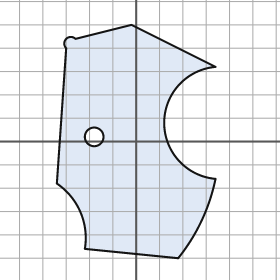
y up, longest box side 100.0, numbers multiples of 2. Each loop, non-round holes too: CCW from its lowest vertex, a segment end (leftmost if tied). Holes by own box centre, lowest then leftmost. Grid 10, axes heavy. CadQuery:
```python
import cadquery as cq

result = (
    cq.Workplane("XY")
    .moveTo(18.0, -50.0)
    .threePointArc((28.0, -34.0), (34.0, -16.0))
    .threePointArc((12.0, 8.0), (34.0, 32.0))
    .lineTo(-2.0, 50.0)
    .lineTo(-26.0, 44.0)
    .threePointArc((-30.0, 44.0), (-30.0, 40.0))
    .lineTo(-34.0, -18.0)
    .threePointArc((-24.0, -30.0), (-22.0, -46.0))
    .close()
    .moveTo(-18.0, 2.0)
    .circle(4.0)
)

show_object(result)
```